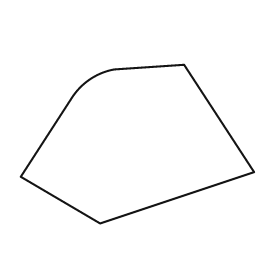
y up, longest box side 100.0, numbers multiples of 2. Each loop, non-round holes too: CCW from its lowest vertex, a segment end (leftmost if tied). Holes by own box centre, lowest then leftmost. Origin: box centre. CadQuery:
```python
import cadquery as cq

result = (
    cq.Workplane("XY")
    .moveTo(-16.0, -34.0)
    .lineTo(50.0, -12.0)
    .lineTo(20.0, 34.0)
    .lineTo(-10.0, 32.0)
    .threePointArc((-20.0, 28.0), (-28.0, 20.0))
    .lineTo(-50.0, -14.0)
    .close()
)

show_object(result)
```